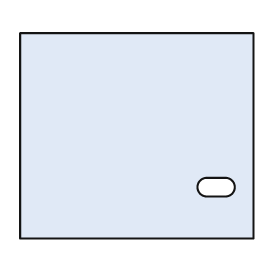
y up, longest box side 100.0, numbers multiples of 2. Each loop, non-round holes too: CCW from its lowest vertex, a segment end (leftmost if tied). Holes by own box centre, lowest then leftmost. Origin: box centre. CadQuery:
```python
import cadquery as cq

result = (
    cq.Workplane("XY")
    .moveTo(-50.0, -44.0)
    .lineTo(50.0, -44.0)
    .lineTo(50.0, 44.0)
    .lineTo(-50.0, 44.0)
    .close()
    .moveTo(30.0, -26.0)
    .lineTo(38.0, -26.0)
    .threePointArc((42.0, -22.0), (38.0, -18.0))
    .lineTo(30.0, -18.0)
    .threePointArc((26.0, -22.0), (30.0, -26.0))
    .close()
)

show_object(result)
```